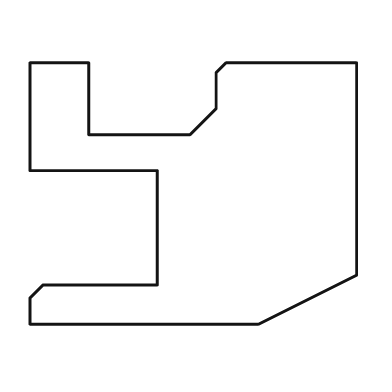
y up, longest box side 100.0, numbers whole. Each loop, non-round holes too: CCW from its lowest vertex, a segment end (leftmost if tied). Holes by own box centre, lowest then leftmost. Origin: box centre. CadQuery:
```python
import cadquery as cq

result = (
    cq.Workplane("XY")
    .moveTo(-50.0, -40.0)
    .lineTo(20.0, -40.0)
    .lineTo(50.0, -25.0)
    .lineTo(50.0, 40.0)
    .lineTo(10.0, 40.0)
    .lineTo(7.0, 37.0)
    .lineTo(7.0, 26.0)
    .lineTo(-1.0, 18.0)
    .lineTo(-32.0, 18.0)
    .lineTo(-32.0, 40.0)
    .lineTo(-50.0, 40.0)
    .lineTo(-50.0, 7.0)
    .lineTo(-11.0, 7.0)
    .lineTo(-11.0, -28.0)
    .lineTo(-46.0, -28.0)
    .lineTo(-50.0, -32.0)
    .close()
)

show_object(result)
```